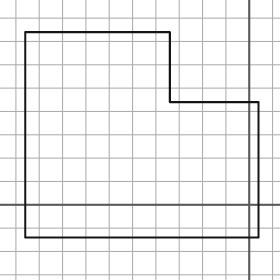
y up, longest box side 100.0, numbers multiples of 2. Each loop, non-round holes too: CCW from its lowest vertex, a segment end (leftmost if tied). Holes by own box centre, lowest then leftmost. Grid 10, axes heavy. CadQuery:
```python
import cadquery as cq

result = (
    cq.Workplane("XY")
    .moveTo(-96.0, -14.0)
    .lineTo(4.0, -14.0)
    .lineTo(4.0, 44.0)
    .lineTo(-34.0, 44.0)
    .lineTo(-34.0, 74.0)
    .lineTo(-96.0, 74.0)
    .close()
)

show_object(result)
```